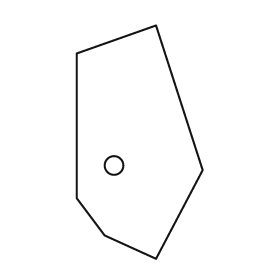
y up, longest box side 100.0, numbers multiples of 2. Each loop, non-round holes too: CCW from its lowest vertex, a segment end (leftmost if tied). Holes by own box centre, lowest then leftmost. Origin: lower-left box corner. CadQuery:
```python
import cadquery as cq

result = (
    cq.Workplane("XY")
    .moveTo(34.0, 0.0)
    .lineTo(54.0, 38.0)
    .lineTo(34.0, 100.0)
    .lineTo(0.0, 88.0)
    .lineTo(0.0, 26.0)
    .lineTo(12.0, 10.0)
    .close()
    .moveTo(16.0, 40.0)
    .circle(4.0)
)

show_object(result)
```